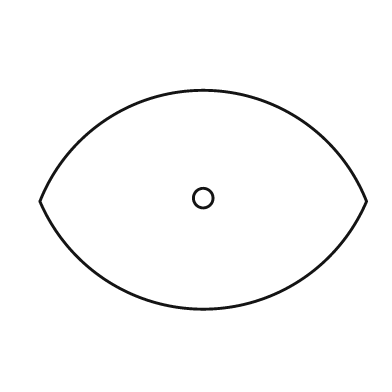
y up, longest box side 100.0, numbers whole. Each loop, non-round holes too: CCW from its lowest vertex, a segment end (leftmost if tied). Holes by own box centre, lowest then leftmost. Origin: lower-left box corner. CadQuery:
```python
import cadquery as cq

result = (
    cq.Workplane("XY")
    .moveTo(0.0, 33.0)
    .threePointArc((50.0, 0.0), (100.0, 33.0))
    .threePointArc((50.0, 67.0), (0.0, 33.0))
    .close()
    .moveTo(50.0, 34.0)
    .circle(3.0)
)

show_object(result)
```